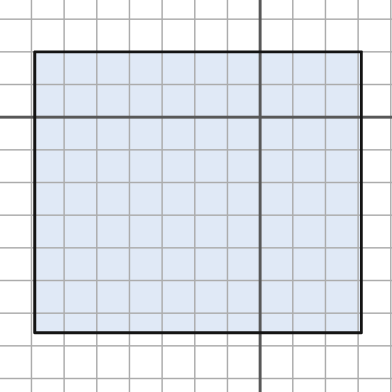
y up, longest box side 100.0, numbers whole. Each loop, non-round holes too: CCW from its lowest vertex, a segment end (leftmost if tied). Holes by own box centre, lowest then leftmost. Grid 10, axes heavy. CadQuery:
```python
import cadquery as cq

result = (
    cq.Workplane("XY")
    .moveTo(-69.0, -66.0)
    .lineTo(31.0, -66.0)
    .lineTo(31.0, 20.0)
    .lineTo(-69.0, 20.0)
    .close()
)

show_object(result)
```